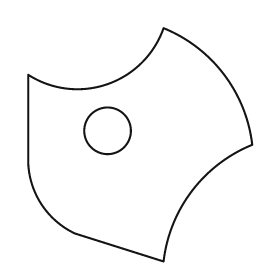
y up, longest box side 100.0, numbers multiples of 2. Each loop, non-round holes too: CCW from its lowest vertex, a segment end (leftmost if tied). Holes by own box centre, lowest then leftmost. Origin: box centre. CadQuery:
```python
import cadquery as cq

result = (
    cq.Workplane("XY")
    .moveTo(10.0, -50.0)
    .threePointArc((22.0, -20.0), (48.0, 0.0))
    .threePointArc((36.0, 30.0), (10.0, 50.0))
    .threePointArc((-14.0, 26.0), (-48.0, 30.0))
    .lineTo(-48.0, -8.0)
    .threePointArc((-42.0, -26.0), (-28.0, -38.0))
    .close()
    .moveTo(-14.0, 6.0)
    .circle(10.0)
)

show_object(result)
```